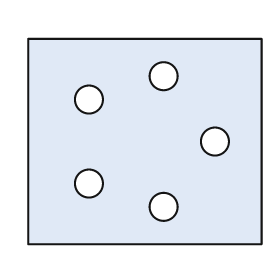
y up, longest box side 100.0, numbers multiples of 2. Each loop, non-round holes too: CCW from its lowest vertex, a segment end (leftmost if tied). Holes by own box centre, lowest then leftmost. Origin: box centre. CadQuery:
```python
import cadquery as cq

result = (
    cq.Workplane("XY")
    .moveTo(-50.0, -44.0)
    .lineTo(50.0, -44.0)
    .lineTo(50.0, 44.0)
    .lineTo(-50.0, 44.0)
    .close()
    .moveTo(8.0, -28.0)
    .circle(6.0)
    .moveTo(-24.0, -18.0)
    .circle(6.0)
    .moveTo(30.0, 0.0)
    .circle(6.0)
    .moveTo(-24.0, 18.0)
    .circle(6.0)
    .moveTo(8.0, 28.0)
    .circle(6.0)
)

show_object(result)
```